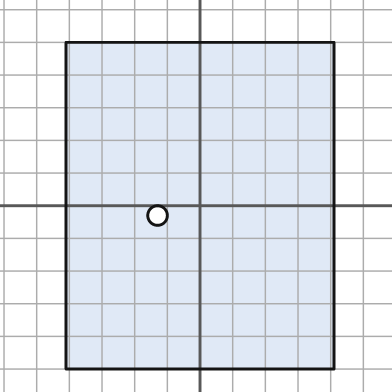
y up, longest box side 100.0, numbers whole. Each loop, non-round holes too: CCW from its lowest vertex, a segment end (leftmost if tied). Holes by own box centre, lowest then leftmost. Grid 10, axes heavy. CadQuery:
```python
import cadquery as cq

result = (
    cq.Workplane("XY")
    .moveTo(-41.0, -50.0)
    .lineTo(41.0, -50.0)
    .lineTo(41.0, 50.0)
    .lineTo(-41.0, 50.0)
    .close()
    .moveTo(-13.0, -3.0)
    .circle(3.0)
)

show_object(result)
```